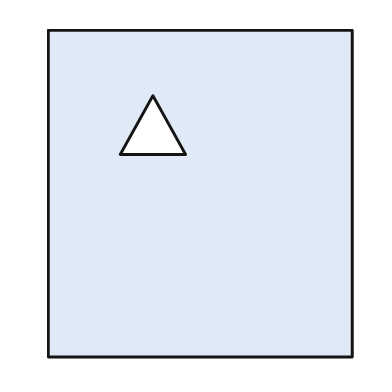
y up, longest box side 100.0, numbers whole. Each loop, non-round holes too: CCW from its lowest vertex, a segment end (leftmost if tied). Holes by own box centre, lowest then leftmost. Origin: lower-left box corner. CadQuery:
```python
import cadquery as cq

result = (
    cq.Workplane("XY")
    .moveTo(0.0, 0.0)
    .lineTo(93.0, 0.0)
    .lineTo(93.0, 100.0)
    .lineTo(0.0, 100.0)
    .close()
    .moveTo(22.0, 62.0)
    .lineTo(42.0, 62.0)
    .lineTo(32.0, 80.0)
    .close()
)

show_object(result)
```